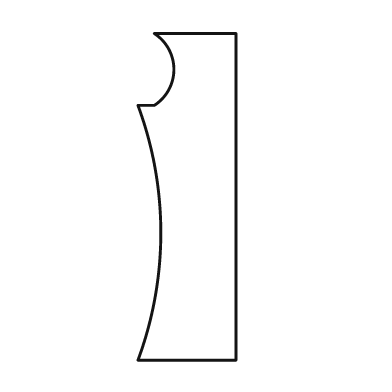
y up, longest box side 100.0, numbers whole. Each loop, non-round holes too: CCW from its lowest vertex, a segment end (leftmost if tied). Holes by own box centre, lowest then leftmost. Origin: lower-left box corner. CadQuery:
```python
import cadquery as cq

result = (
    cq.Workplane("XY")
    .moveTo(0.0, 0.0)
    .lineTo(30.0, 0.0)
    .lineTo(30.0, 100.0)
    .lineTo(5.0, 100.0)
    .threePointArc((11.0, 89.0), (5.0, 78.0))
    .lineTo(0.0, 78.0)
    .threePointArc((7.0, 39.0), (0.0, 0.0))
    .close()
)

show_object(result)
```